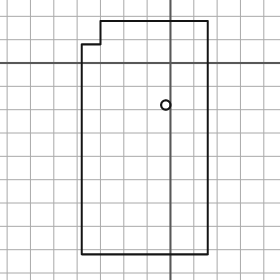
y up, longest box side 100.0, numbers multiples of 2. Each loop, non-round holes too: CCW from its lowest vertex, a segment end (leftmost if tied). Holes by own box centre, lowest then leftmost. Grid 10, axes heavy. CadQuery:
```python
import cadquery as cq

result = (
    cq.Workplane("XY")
    .moveTo(-38.0, -82.0)
    .lineTo(16.0, -82.0)
    .lineTo(16.0, 18.0)
    .lineTo(-30.0, 18.0)
    .lineTo(-30.0, 8.0)
    .lineTo(-38.0, 8.0)
    .close()
    .moveTo(-2.0, -18.0)
    .circle(2.0)
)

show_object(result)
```